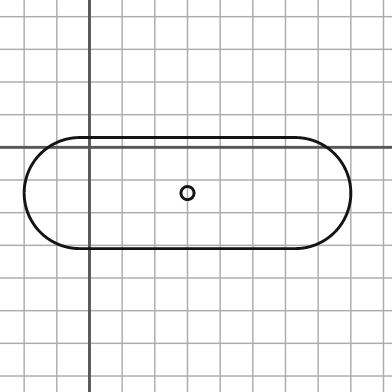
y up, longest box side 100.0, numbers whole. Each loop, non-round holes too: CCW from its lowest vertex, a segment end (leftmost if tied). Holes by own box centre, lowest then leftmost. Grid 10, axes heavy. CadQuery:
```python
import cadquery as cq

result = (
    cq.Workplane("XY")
    .moveTo(-3.0, -31.0)
    .lineTo(63.0, -31.0)
    .threePointArc((80.0, -14.0), (63.0, 3.0))
    .lineTo(-3.0, 3.0)
    .threePointArc((-20.0, -14.0), (-3.0, -31.0))
    .close()
    .moveTo(30.0, -14.0)
    .circle(2.0)
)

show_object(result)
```